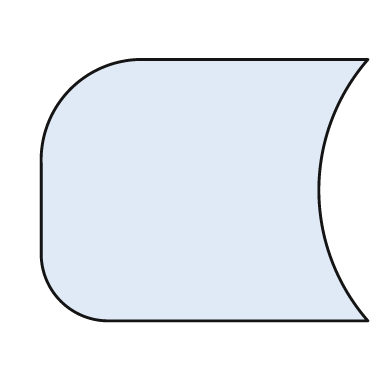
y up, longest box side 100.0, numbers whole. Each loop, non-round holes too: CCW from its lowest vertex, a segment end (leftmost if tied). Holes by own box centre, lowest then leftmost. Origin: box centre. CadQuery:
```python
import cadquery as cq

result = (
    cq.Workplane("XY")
    .moveTo(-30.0, -40.0)
    .lineTo(50.0, -40.0)
    .threePointArc((35.0, 0.0), (50.0, 40.0))
    .lineTo(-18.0, 40.0)
    .threePointArc((-41.0, 31.0), (-50.0, 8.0))
    .lineTo(-50.0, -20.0)
    .threePointArc((-44.0, -34.0), (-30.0, -40.0))
    .close()
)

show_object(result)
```